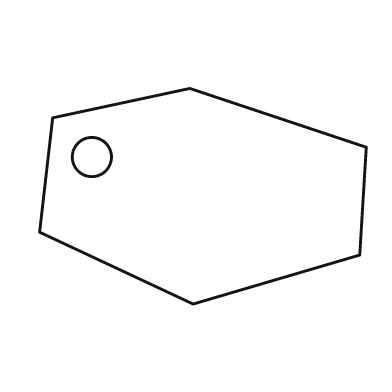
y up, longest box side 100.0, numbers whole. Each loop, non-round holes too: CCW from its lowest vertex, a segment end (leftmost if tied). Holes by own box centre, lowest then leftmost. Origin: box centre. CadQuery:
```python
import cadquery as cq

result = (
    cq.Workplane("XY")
    .moveTo(-3.0, -33.0)
    .lineTo(48.0, -18.0)
    .lineTo(50.0, 15.0)
    .lineTo(-4.0, 33.0)
    .lineTo(-46.0, 24.0)
    .lineTo(-50.0, -11.0)
    .close()
    .moveTo(-34.0, 12.0)
    .circle(6.0)
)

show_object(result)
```